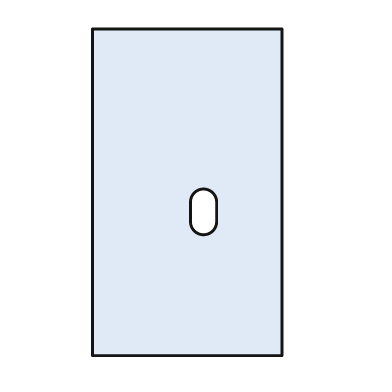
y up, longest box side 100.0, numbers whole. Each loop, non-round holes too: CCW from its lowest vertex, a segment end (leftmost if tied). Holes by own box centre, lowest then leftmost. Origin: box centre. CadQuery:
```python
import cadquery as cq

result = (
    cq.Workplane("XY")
    .moveTo(-29.0, -50.0)
    .lineTo(29.0, -50.0)
    .lineTo(29.0, 50.0)
    .lineTo(-29.0, 50.0)
    .close()
    .moveTo(1.0, -9.0)
    .threePointArc((5.0, -13.0), (9.0, -9.0))
    .lineTo(9.0, -3.0)
    .threePointArc((5.0, 1.0), (1.0, -3.0))
    .close()
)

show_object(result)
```